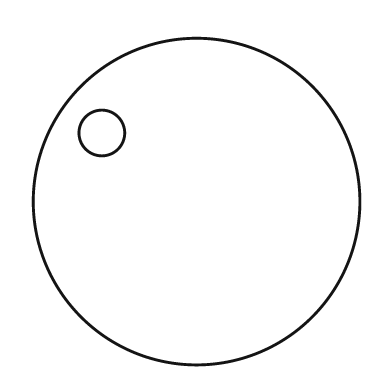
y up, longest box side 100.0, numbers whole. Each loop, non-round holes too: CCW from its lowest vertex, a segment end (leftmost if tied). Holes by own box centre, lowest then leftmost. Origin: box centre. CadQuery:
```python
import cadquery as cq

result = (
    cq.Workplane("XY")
    .moveTo(0.0, 0.0)
    .circle(50.0)
    .moveTo(-29.0, 21.0)
    .circle(7.0)
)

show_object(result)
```